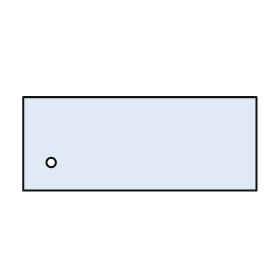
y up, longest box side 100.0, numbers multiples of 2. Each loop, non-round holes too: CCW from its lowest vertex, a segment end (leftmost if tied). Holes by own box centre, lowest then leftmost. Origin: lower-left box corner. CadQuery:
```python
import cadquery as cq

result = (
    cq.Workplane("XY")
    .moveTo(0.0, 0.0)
    .lineTo(100.0, 0.0)
    .lineTo(100.0, 40.0)
    .lineTo(0.0, 40.0)
    .close()
    .moveTo(12.0, 12.0)
    .circle(2.0)
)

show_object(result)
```